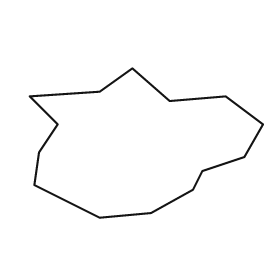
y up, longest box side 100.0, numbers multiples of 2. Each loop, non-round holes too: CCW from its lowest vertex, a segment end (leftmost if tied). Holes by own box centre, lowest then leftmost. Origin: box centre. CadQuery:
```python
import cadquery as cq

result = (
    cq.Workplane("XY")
    .moveTo(-20.0, -32.0)
    .lineTo(2.0, -30.0)
    .lineTo(20.0, -20.0)
    .lineTo(24.0, -12.0)
    .lineTo(42.0, -6.0)
    .lineTo(50.0, 8.0)
    .lineTo(34.0, 20.0)
    .lineTo(10.0, 18.0)
    .lineTo(-6.0, 32.0)
    .lineTo(-20.0, 22.0)
    .lineTo(-50.0, 20.0)
    .lineTo(-38.0, 8.0)
    .lineTo(-46.0, -4.0)
    .lineTo(-48.0, -18.0)
    .close()
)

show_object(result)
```